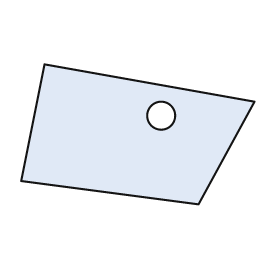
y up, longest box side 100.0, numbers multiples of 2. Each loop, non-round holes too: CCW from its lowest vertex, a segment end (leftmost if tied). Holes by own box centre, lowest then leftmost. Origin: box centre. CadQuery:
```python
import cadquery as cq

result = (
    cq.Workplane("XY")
    .moveTo(26.0, -30.0)
    .lineTo(50.0, 14.0)
    .lineTo(-40.0, 30.0)
    .lineTo(-50.0, -20.0)
    .close()
    .moveTo(10.0, 8.0)
    .circle(6.0)
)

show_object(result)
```